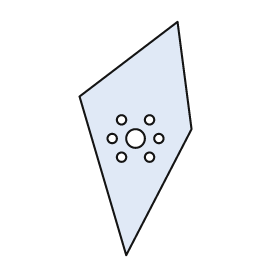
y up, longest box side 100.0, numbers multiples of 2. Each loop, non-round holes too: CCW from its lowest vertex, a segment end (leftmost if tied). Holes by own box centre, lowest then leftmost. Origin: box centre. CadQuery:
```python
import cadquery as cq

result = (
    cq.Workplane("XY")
    .moveTo(-4.0, -50.0)
    .lineTo(24.0, 4.0)
    .lineTo(18.0, 50.0)
    .lineTo(-24.0, 18.0)
    .close()
    .moveTo(-6.0, -8.0)
    .circle(2.0)
    .moveTo(6.0, -8.0)
    .circle(2.0)
    .moveTo(-10.0, 0.0)
    .circle(2.0)
    .moveTo(0.0, 0.0)
    .circle(4.0)
    .moveTo(10.0, 0.0)
    .circle(2.0)
    .moveTo(-6.0, 8.0)
    .circle(2.0)
    .moveTo(6.0, 8.0)
    .circle(2.0)
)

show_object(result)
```